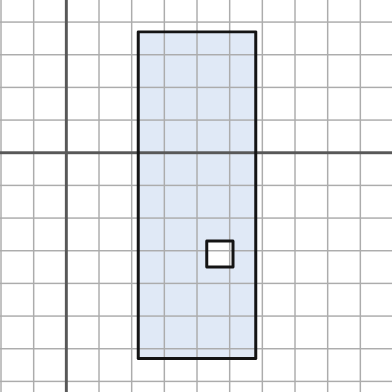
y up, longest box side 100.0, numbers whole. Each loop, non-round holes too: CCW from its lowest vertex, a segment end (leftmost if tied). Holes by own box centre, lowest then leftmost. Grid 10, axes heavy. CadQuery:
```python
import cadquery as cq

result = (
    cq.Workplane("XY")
    .moveTo(22.0, -63.0)
    .lineTo(58.0, -63.0)
    .lineTo(58.0, 37.0)
    .lineTo(22.0, 37.0)
    .close()
    .moveTo(43.0, -35.0)
    .lineTo(51.0, -35.0)
    .lineTo(51.0, -27.0)
    .lineTo(43.0, -27.0)
    .close()
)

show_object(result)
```